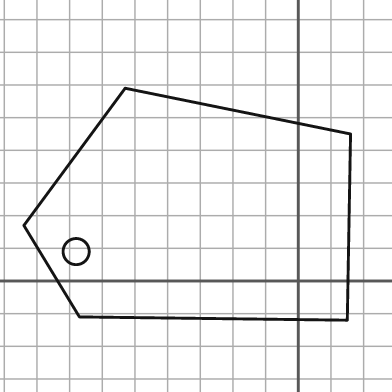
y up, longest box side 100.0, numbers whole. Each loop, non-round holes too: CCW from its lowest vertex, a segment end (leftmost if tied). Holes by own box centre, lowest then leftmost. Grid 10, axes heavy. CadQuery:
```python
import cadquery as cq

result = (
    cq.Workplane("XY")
    .moveTo(15.0, -12.0)
    .lineTo(16.0, 45.0)
    .lineTo(-53.0, 59.0)
    .lineTo(-84.0, 17.0)
    .lineTo(-67.0, -11.0)
    .close()
    .moveTo(-68.0, 9.0)
    .circle(4.0)
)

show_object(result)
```